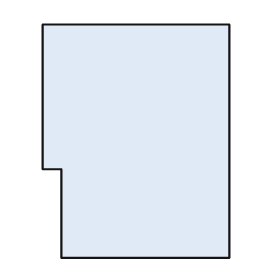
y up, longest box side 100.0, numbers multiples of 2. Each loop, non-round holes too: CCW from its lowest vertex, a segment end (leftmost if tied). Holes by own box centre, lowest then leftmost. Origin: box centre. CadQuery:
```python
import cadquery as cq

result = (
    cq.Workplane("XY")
    .moveTo(-32.0, -50.0)
    .lineTo(40.0, -50.0)
    .lineTo(40.0, 50.0)
    .lineTo(-40.0, 50.0)
    .lineTo(-40.0, -12.0)
    .lineTo(-32.0, -12.0)
    .close()
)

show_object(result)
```